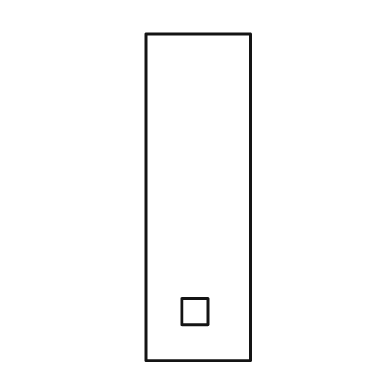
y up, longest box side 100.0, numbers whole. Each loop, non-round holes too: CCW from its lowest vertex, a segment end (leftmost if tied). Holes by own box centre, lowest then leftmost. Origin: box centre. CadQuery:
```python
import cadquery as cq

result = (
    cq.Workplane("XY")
    .moveTo(-16.0, -50.0)
    .lineTo(16.0, -50.0)
    .lineTo(16.0, 50.0)
    .lineTo(-16.0, 50.0)
    .close()
    .moveTo(-5.0, -39.0)
    .lineTo(3.0, -39.0)
    .lineTo(3.0, -31.0)
    .lineTo(-5.0, -31.0)
    .close()
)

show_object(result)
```